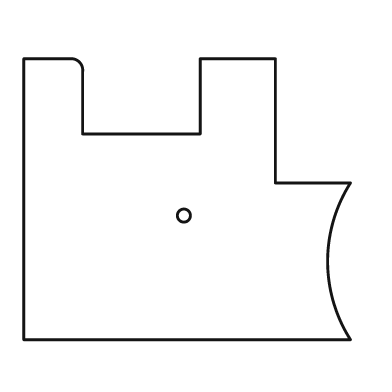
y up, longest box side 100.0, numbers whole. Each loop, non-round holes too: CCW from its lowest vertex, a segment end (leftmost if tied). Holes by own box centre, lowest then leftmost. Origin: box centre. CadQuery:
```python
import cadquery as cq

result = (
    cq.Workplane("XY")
    .moveTo(-50.0, -43.0)
    .lineTo(50.0, -43.0)
    .threePointArc((43.0, -19.0), (50.0, 5.0))
    .lineTo(27.0, 5.0)
    .lineTo(27.0, 43.0)
    .lineTo(4.0, 43.0)
    .lineTo(4.0, 20.0)
    .lineTo(-32.0, 20.0)
    .lineTo(-32.0, 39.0)
    .threePointArc((-33.0, 42.0), (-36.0, 43.0))
    .lineTo(-50.0, 43.0)
    .close()
    .moveTo(-1.0, -5.0)
    .circle(2.0)
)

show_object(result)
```